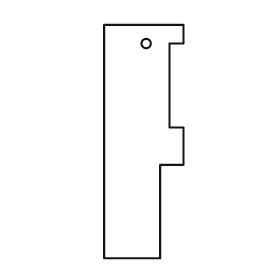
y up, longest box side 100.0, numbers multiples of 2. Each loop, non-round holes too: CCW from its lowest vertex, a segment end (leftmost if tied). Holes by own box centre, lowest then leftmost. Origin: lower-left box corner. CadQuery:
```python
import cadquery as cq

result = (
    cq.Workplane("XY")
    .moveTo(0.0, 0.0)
    .lineTo(24.0, 0.0)
    .lineTo(24.0, 40.0)
    .lineTo(34.0, 40.0)
    .lineTo(34.0, 56.0)
    .lineTo(28.0, 56.0)
    .lineTo(28.0, 92.0)
    .lineTo(34.0, 92.0)
    .lineTo(34.0, 100.0)
    .lineTo(0.0, 100.0)
    .close()
    .moveTo(18.0, 92.0)
    .circle(2.0)
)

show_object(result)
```